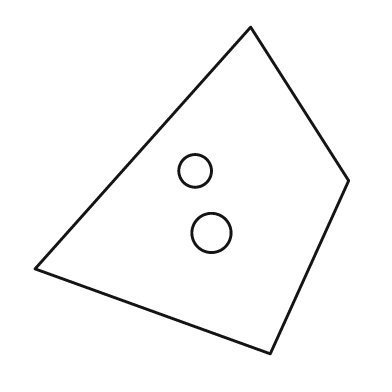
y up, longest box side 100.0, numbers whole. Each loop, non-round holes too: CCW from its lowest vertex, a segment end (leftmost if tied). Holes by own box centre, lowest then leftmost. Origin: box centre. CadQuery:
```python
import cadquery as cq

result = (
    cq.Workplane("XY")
    .moveTo(24.0, -50.0)
    .lineTo(48.0, 3.0)
    .lineTo(18.0, 50.0)
    .lineTo(-48.0, -24.0)
    .close()
    .moveTo(6.0, -13.0)
    .circle(6.0)
    .moveTo(1.0, 6.0)
    .circle(5.0)
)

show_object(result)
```